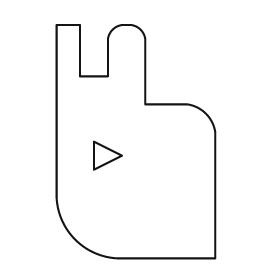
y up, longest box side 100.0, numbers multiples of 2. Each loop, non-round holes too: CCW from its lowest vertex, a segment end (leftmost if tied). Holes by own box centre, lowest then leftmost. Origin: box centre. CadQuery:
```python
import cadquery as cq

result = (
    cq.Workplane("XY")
    .moveTo(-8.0, -50.0)
    .lineTo(34.0, -50.0)
    .lineTo(34.0, 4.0)
    .threePointArc((30.0, 12.0), (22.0, 16.0))
    .lineTo(4.0, 16.0)
    .lineTo(4.0, 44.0)
    .threePointArc((2.0, 48.0), (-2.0, 50.0))
    .lineTo(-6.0, 50.0)
    .threePointArc((-10.0, 48.0), (-12.0, 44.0))
    .lineTo(-12.0, 28.0)
    .lineTo(-24.0, 28.0)
    .lineTo(-24.0, 50.0)
    .lineTo(-34.0, 50.0)
    .lineTo(-34.0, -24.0)
    .threePointArc((-26.0, -42.0), (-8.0, -50.0))
    .close()
    .moveTo(-18.0, -12.0)
    .lineTo(-6.0, -6.0)
    .lineTo(-18.0, 0.0)
    .close()
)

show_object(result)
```